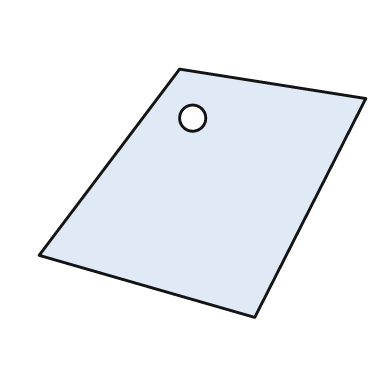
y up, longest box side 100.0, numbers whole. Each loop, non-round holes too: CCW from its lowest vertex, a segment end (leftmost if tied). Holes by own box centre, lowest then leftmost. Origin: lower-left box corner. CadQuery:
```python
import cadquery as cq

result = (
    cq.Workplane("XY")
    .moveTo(66.0, 0.0)
    .lineTo(100.0, 67.0)
    .lineTo(43.0, 76.0)
    .lineTo(0.0, 19.0)
    .close()
    .moveTo(47.0, 61.0)
    .circle(4.0)
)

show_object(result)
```